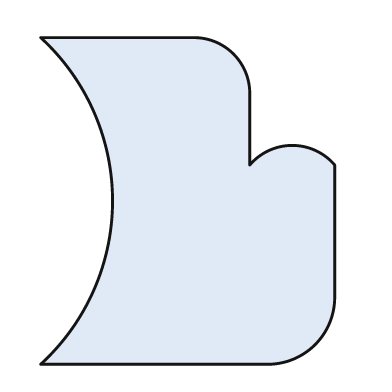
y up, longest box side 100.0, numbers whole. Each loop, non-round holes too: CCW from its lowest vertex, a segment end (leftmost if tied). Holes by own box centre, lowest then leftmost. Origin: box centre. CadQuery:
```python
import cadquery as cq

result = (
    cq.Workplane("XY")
    .moveTo(-45.0, -50.0)
    .lineTo(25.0, -50.0)
    .threePointArc((39.0, -44.0), (45.0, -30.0))
    .lineTo(45.0, 11.0)
    .threePointArc((32.0, 17.0), (19.0, 11.0))
    .lineTo(19.0, 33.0)
    .threePointArc((14.0, 45.0), (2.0, 50.0))
    .lineTo(-45.0, 50.0)
    .threePointArc((-23.0, 0.0), (-45.0, -50.0))
    .close()
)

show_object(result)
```